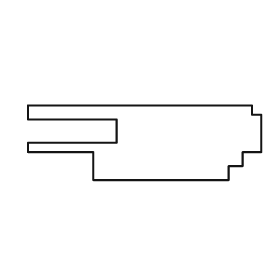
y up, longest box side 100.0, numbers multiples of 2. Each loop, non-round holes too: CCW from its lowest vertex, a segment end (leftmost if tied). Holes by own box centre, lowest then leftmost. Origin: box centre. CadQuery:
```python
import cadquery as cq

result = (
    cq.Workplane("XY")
    .moveTo(-22.0, -16.0)
    .lineTo(36.0, -16.0)
    .lineTo(36.0, -10.0)
    .lineTo(42.0, -10.0)
    .lineTo(42.0, -4.0)
    .lineTo(50.0, -4.0)
    .lineTo(50.0, 12.0)
    .lineTo(46.0, 12.0)
    .lineTo(46.0, 16.0)
    .lineTo(-50.0, 16.0)
    .lineTo(-50.0, 10.0)
    .lineTo(-12.0, 10.0)
    .lineTo(-12.0, 0.0)
    .lineTo(-50.0, 0.0)
    .lineTo(-50.0, -4.0)
    .lineTo(-22.0, -4.0)
    .close()
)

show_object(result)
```